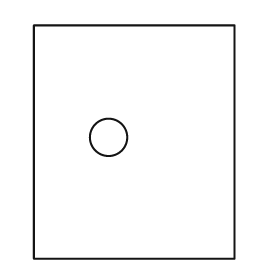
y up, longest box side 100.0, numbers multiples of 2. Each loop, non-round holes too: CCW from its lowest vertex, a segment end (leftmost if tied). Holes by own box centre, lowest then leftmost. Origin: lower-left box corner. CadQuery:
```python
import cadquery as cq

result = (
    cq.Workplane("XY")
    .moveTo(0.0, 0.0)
    .lineTo(86.0, 0.0)
    .lineTo(86.0, 100.0)
    .lineTo(0.0, 100.0)
    .close()
    .moveTo(32.0, 52.0)
    .circle(8.0)
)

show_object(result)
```